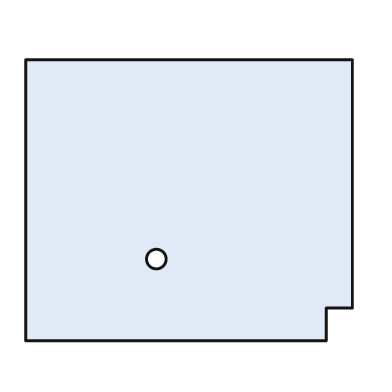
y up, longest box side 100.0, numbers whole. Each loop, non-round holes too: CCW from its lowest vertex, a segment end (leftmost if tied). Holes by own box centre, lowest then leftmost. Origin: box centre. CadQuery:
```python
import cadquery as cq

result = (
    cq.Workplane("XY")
    .moveTo(-50.0, -43.0)
    .lineTo(42.0, -43.0)
    .lineTo(42.0, -33.0)
    .lineTo(50.0, -33.0)
    .lineTo(50.0, 43.0)
    .lineTo(-50.0, 43.0)
    .close()
    .moveTo(-10.0, -18.0)
    .circle(3.0)
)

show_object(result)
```